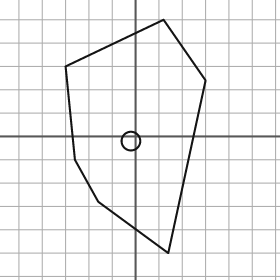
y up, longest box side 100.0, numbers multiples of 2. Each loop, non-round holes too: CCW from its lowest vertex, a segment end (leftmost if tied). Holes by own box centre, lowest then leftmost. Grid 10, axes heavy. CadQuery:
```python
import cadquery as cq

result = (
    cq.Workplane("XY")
    .moveTo(14.0, -50.0)
    .lineTo(30.0, 24.0)
    .lineTo(12.0, 50.0)
    .lineTo(-30.0, 30.0)
    .lineTo(-26.0, -10.0)
    .lineTo(-16.0, -28.0)
    .close()
    .moveTo(-2.0, -2.0)
    .circle(4.0)
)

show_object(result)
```